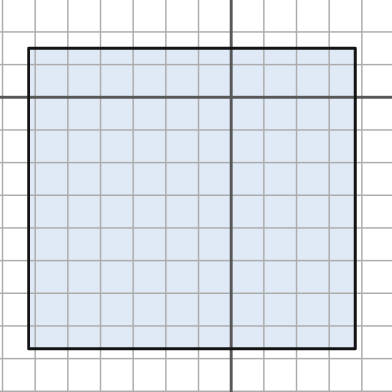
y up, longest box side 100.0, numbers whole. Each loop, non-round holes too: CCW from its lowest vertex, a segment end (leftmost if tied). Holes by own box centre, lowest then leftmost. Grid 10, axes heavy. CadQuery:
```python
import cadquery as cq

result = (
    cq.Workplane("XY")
    .moveTo(-62.0, -77.0)
    .lineTo(38.0, -77.0)
    .lineTo(38.0, 15.0)
    .lineTo(-62.0, 15.0)
    .close()
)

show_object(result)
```